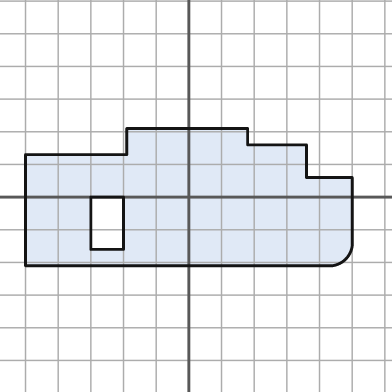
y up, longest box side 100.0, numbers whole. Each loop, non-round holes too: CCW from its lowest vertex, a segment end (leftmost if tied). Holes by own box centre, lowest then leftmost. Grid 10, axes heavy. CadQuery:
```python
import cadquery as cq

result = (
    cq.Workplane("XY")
    .moveTo(-50.0, -21.0)
    .lineTo(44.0, -21.0)
    .threePointArc((48.0, -19.0), (50.0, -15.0))
    .lineTo(50.0, 6.0)
    .lineTo(36.0, 6.0)
    .lineTo(36.0, 16.0)
    .lineTo(18.0, 16.0)
    .lineTo(18.0, 21.0)
    .lineTo(-19.0, 21.0)
    .lineTo(-19.0, 13.0)
    .lineTo(-50.0, 13.0)
    .close()
    .moveTo(-30.0, -16.0)
    .lineTo(-20.0, -16.0)
    .lineTo(-20.0, 0.0)
    .lineTo(-30.0, 0.0)
    .close()
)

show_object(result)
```